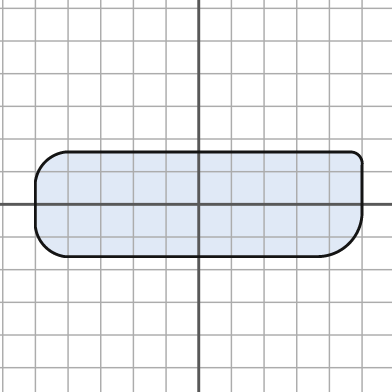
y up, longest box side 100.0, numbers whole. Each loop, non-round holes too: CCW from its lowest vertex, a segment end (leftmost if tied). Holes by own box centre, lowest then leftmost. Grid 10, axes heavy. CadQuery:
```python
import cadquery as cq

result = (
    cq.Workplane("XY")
    .moveTo(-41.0, -16.0)
    .lineTo(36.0, -16.0)
    .threePointArc((46.0, -12.0), (50.0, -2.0))
    .lineTo(50.0, 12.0)
    .threePointArc((49.0, 15.0), (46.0, 16.0))
    .lineTo(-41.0, 16.0)
    .threePointArc((-47.0, 13.0), (-50.0, 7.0))
    .lineTo(-50.0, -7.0)
    .threePointArc((-47.0, -13.0), (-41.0, -16.0))
    .close()
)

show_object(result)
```